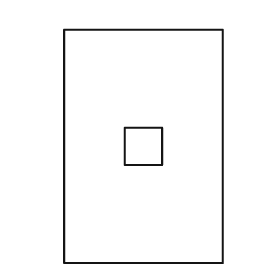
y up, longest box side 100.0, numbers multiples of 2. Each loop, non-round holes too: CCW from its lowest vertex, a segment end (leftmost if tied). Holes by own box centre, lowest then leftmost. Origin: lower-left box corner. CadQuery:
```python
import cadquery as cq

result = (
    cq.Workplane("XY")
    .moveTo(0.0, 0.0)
    .lineTo(68.0, 0.0)
    .lineTo(68.0, 100.0)
    .lineTo(0.0, 100.0)
    .close()
    .moveTo(26.0, 42.0)
    .lineTo(42.0, 42.0)
    .lineTo(42.0, 58.0)
    .lineTo(26.0, 58.0)
    .close()
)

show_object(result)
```